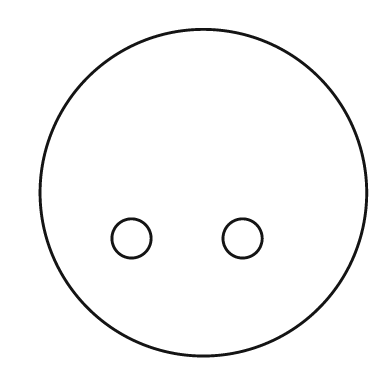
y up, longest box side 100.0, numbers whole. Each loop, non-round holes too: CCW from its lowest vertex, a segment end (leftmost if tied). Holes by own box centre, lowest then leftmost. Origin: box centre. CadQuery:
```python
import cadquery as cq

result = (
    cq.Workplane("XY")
    .moveTo(0.0, 0.0)
    .circle(50.0)
    .moveTo(-22.0, -14.0)
    .circle(6.0)
    .moveTo(12.0, -14.0)
    .circle(6.0)
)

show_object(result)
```